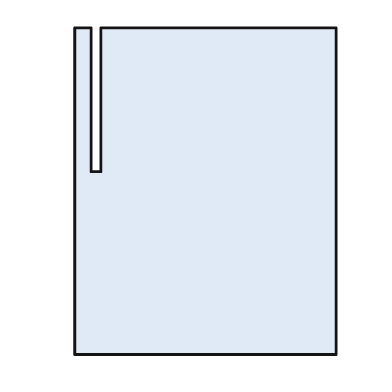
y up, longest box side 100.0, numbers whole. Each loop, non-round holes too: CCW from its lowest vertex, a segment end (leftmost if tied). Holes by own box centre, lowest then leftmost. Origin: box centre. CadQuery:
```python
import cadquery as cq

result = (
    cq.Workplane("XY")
    .moveTo(-40.0, -50.0)
    .lineTo(40.0, -50.0)
    .lineTo(40.0, 50.0)
    .lineTo(-32.0, 50.0)
    .lineTo(-32.0, 6.0)
    .lineTo(-35.0, 6.0)
    .lineTo(-35.0, 50.0)
    .lineTo(-40.0, 50.0)
    .close()
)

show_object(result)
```